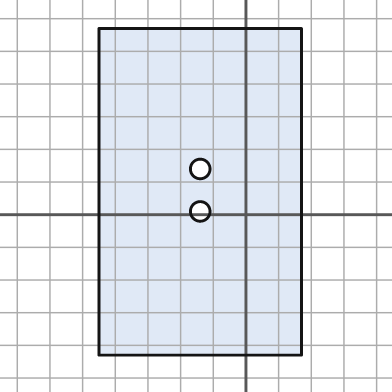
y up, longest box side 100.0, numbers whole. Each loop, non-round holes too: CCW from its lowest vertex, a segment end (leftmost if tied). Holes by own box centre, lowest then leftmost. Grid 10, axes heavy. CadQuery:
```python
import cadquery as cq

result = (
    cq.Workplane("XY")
    .moveTo(-45.0, -43.0)
    .lineTo(17.0, -43.0)
    .lineTo(17.0, 57.0)
    .lineTo(-45.0, 57.0)
    .close()
    .moveTo(-14.0, 1.0)
    .circle(3.0)
    .moveTo(-14.0, 14.0)
    .circle(3.0)
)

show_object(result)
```